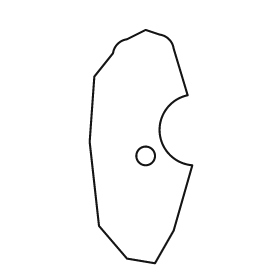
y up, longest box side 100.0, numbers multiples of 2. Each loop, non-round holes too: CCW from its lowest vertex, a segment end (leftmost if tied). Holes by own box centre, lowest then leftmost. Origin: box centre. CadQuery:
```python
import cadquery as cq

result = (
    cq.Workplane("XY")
    .moveTo(6.0, -50.0)
    .lineTo(14.0, -36.0)
    .lineTo(22.0, -8.0)
    .threePointArc((8.0, 6.0), (20.0, 22.0))
    .lineTo(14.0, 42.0)
    .threePointArc((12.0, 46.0), (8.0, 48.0))
    .lineTo(2.0, 50.0)
    .lineTo(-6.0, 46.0)
    .threePointArc((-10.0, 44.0), (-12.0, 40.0))
    .lineTo(-20.0, 30.0)
    .lineTo(-22.0, 2.0)
    .lineTo(-18.0, -34.0)
    .lineTo(-6.0, -48.0)
    .close()
    .moveTo(2.0, -4.0)
    .circle(4.0)
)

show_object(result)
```